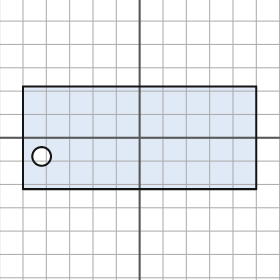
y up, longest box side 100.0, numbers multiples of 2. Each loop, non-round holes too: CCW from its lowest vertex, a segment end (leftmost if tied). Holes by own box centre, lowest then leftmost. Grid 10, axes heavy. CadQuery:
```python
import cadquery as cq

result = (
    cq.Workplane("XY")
    .moveTo(-50.0, -22.0)
    .lineTo(50.0, -22.0)
    .lineTo(50.0, 22.0)
    .lineTo(-50.0, 22.0)
    .close()
    .moveTo(-42.0, -8.0)
    .circle(4.0)
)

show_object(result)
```